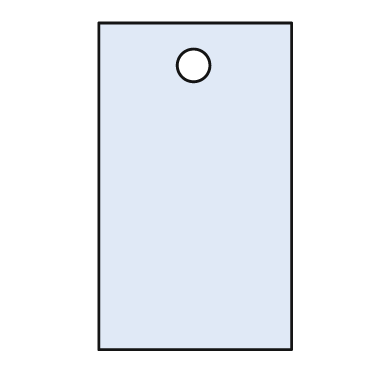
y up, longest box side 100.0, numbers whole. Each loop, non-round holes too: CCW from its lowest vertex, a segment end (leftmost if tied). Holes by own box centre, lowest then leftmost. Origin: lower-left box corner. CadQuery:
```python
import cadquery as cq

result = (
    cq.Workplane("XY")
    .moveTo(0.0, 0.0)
    .lineTo(59.0, 0.0)
    .lineTo(59.0, 100.0)
    .lineTo(0.0, 100.0)
    .close()
    .moveTo(29.0, 87.0)
    .circle(5.0)
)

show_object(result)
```